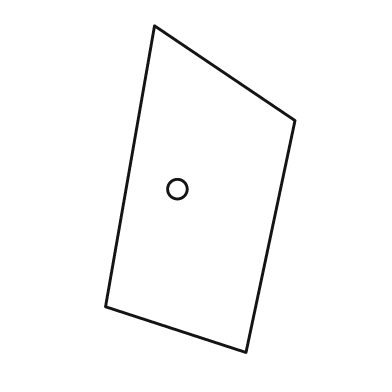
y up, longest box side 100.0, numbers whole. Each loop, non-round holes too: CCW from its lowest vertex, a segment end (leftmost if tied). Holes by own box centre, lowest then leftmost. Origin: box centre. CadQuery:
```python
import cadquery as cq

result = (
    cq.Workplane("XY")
    .moveTo(14.0, -50.0)
    .lineTo(29.0, 21.0)
    .lineTo(-14.0, 50.0)
    .lineTo(-29.0, -36.0)
    .close()
    .moveTo(-7.0, 0.0)
    .circle(3.0)
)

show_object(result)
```